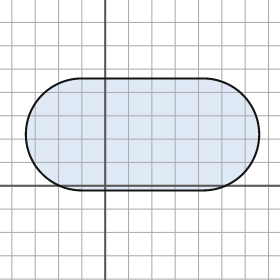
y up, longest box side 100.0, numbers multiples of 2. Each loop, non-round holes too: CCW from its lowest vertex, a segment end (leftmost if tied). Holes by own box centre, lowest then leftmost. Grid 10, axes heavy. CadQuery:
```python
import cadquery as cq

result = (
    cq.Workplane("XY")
    .moveTo(-10.0, -2.0)
    .lineTo(42.0, -2.0)
    .threePointArc((66.0, 22.0), (42.0, 46.0))
    .lineTo(-10.0, 46.0)
    .threePointArc((-34.0, 22.0), (-10.0, -2.0))
    .close()
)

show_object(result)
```